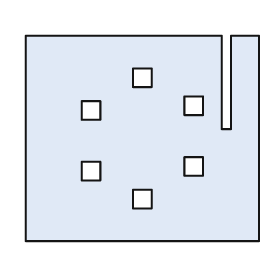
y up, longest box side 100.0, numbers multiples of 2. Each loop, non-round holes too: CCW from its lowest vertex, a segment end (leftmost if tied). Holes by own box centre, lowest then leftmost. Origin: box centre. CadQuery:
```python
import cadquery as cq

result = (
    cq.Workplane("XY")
    .moveTo(-50.0, -44.0)
    .lineTo(50.0, -44.0)
    .lineTo(50.0, 44.0)
    .lineTo(38.0, 44.0)
    .lineTo(38.0, 4.0)
    .lineTo(34.0, 4.0)
    .lineTo(34.0, 44.0)
    .lineTo(-50.0, 44.0)
    .close()
    .moveTo(-4.0, -30.0)
    .lineTo(4.0, -30.0)
    .lineTo(4.0, -22.0)
    .lineTo(-4.0, -22.0)
    .close()
    .moveTo(-26.0, -18.0)
    .lineTo(-18.0, -18.0)
    .lineTo(-18.0, -10.0)
    .lineTo(-26.0, -10.0)
    .close()
    .moveTo(18.0, -16.0)
    .lineTo(26.0, -16.0)
    .lineTo(26.0, -8.0)
    .lineTo(18.0, -8.0)
    .close()
    .moveTo(-26.0, 8.0)
    .lineTo(-18.0, 8.0)
    .lineTo(-18.0, 16.0)
    .lineTo(-26.0, 16.0)
    .close()
    .moveTo(18.0, 10.0)
    .lineTo(26.0, 10.0)
    .lineTo(26.0, 18.0)
    .lineTo(18.0, 18.0)
    .close()
    .moveTo(-4.0, 22.0)
    .lineTo(4.0, 22.0)
    .lineTo(4.0, 30.0)
    .lineTo(-4.0, 30.0)
    .close()
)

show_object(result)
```